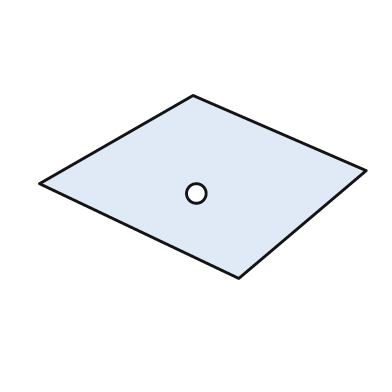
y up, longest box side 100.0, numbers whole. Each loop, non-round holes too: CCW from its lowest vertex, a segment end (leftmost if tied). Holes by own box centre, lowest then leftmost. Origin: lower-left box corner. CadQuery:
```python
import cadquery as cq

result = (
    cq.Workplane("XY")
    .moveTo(61.0, 0.0)
    .lineTo(100.0, 33.0)
    .lineTo(47.0, 56.0)
    .lineTo(0.0, 29.0)
    .close()
    .moveTo(48.0, 26.0)
    .circle(3.0)
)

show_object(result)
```